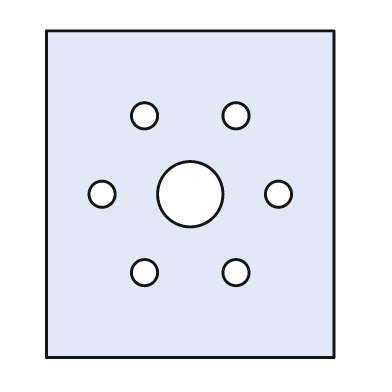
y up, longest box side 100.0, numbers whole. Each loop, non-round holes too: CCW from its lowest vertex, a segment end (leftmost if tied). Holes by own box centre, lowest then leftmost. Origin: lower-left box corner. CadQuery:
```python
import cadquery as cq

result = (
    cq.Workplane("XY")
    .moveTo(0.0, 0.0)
    .lineTo(88.0, 0.0)
    .lineTo(88.0, 100.0)
    .lineTo(0.0, 100.0)
    .close()
    .moveTo(30.0, 26.0)
    .circle(4.0)
    .moveTo(58.0, 26.0)
    .circle(4.0)
    .moveTo(17.0, 50.0)
    .circle(4.0)
    .moveTo(44.0, 50.0)
    .circle(10.0)
    .moveTo(71.0, 50.0)
    .circle(4.0)
    .moveTo(30.0, 74.0)
    .circle(4.0)
    .moveTo(58.0, 74.0)
    .circle(4.0)
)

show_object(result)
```